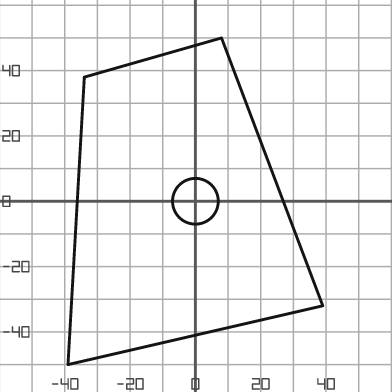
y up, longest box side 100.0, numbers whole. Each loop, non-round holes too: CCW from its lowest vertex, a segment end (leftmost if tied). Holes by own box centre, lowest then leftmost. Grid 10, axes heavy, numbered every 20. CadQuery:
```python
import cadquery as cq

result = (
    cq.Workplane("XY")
    .moveTo(-39.0, -50.0)
    .lineTo(39.0, -32.0)
    .lineTo(8.0, 50.0)
    .lineTo(-34.0, 38.0)
    .close()
    .moveTo(0.0, 0.0)
    .circle(7.0)
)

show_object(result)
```